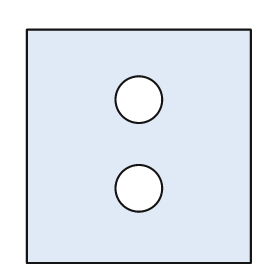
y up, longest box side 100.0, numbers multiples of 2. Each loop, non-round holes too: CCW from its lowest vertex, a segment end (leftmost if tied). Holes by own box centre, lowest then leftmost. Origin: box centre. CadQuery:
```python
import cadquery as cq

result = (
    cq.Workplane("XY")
    .moveTo(-48.0, -50.0)
    .lineTo(48.0, -50.0)
    .lineTo(48.0, 50.0)
    .lineTo(-48.0, 50.0)
    .close()
    .moveTo(0.0, -18.0)
    .circle(10.0)
    .moveTo(0.0, 20.0)
    .circle(10.0)
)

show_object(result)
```